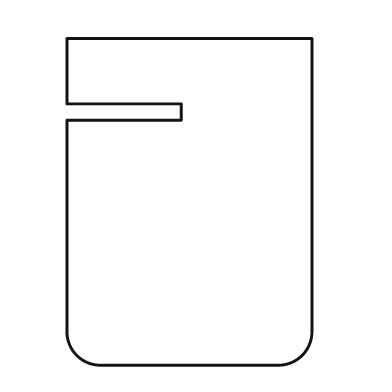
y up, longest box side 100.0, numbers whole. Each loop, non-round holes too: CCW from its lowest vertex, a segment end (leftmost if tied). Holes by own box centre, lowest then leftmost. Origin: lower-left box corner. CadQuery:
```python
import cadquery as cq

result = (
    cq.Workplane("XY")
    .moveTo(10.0, 0.0)
    .lineTo(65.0, 0.0)
    .threePointArc((72.0, 3.0), (75.0, 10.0))
    .lineTo(75.0, 100.0)
    .lineTo(0.0, 100.0)
    .lineTo(0.0, 80.0)
    .lineTo(35.0, 80.0)
    .lineTo(35.0, 75.0)
    .lineTo(0.0, 75.0)
    .lineTo(0.0, 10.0)
    .threePointArc((3.0, 3.0), (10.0, 0.0))
    .close()
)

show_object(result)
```